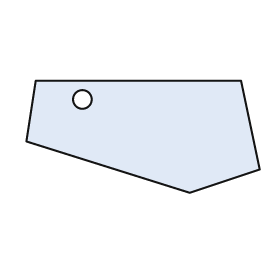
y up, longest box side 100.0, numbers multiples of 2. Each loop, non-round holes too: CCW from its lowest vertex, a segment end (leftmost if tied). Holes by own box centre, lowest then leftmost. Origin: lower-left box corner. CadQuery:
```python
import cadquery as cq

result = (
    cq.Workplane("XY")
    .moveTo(70.0, 0.0)
    .lineTo(100.0, 10.0)
    .lineTo(92.0, 48.0)
    .lineTo(4.0, 48.0)
    .lineTo(0.0, 22.0)
    .close()
    .moveTo(24.0, 40.0)
    .circle(4.0)
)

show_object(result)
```